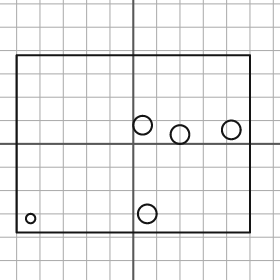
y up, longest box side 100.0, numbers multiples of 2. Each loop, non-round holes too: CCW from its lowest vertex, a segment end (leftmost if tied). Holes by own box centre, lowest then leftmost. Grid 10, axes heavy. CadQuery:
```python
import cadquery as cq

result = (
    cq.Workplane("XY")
    .moveTo(-50.0, -38.0)
    .lineTo(50.0, -38.0)
    .lineTo(50.0, 38.0)
    .lineTo(-50.0, 38.0)
    .close()
    .moveTo(-44.0, -32.0)
    .circle(2.0)
    .moveTo(6.0, -30.0)
    .circle(4.0)
    .moveTo(20.0, 4.0)
    .circle(4.0)
    .moveTo(42.0, 6.0)
    .circle(4.0)
    .moveTo(4.0, 8.0)
    .circle(4.0)
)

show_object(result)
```